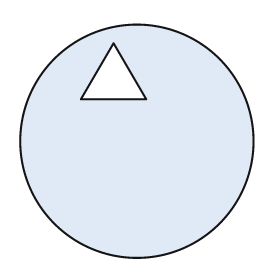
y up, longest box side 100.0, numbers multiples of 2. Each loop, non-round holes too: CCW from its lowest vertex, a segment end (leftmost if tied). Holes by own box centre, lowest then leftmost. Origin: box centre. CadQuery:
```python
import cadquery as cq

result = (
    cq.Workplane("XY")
    .moveTo(0.0, 0.0)
    .circle(50.0)
    .moveTo(-24.0, 18.0)
    .lineTo(4.0, 18.0)
    .lineTo(-10.0, 42.0)
    .close()
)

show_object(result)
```